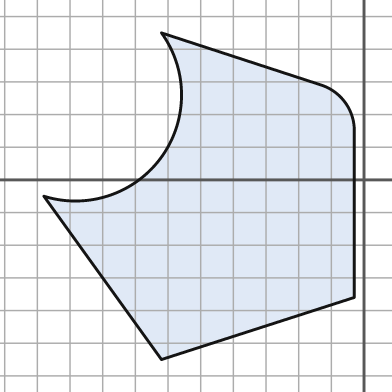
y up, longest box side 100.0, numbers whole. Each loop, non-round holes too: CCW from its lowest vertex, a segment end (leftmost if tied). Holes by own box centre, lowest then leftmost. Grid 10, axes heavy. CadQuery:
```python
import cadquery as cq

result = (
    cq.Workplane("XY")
    .moveTo(-62.0, -55.0)
    .lineTo(-3.0, -36.0)
    .lineTo(-3.0, 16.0)
    .threePointArc((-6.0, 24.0), (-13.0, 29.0))
    .lineTo(-62.0, 45.0)
    .threePointArc((-62.0, 7.0), (-98.0, -5.0))
    .close()
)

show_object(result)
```